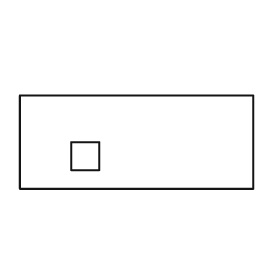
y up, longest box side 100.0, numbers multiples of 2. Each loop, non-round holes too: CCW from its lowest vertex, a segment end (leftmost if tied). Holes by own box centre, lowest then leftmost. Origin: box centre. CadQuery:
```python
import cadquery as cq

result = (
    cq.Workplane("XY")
    .moveTo(-50.0, -20.0)
    .lineTo(50.0, -20.0)
    .lineTo(50.0, 20.0)
    .lineTo(-50.0, 20.0)
    .close()
    .moveTo(-28.0, -12.0)
    .lineTo(-16.0, -12.0)
    .lineTo(-16.0, 0.0)
    .lineTo(-28.0, 0.0)
    .close()
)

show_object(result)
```